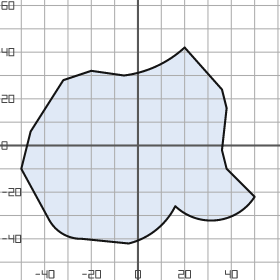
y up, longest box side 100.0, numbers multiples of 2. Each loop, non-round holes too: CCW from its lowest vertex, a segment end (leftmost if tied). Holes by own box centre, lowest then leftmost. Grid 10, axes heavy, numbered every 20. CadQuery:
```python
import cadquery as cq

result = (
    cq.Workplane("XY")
    .moveTo(-4.0, -42.0)
    .threePointArc((8.0, -36.0), (16.0, -26.0))
    .threePointArc((34.0, -32.0), (50.0, -22.0))
    .lineTo(38.0, -10.0)
    .lineTo(36.0, -2.0)
    .lineTo(38.0, 16.0)
    .lineTo(36.0, 24.0)
    .lineTo(20.0, 42.0)
    .threePointArc((8.0, 34.0), (-6.0, 30.0))
    .lineTo(-20.0, 32.0)
    .lineTo(-32.0, 28.0)
    .lineTo(-46.0, 6.0)
    .lineTo(-50.0, -10.0)
    .lineTo(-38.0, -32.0)
    .threePointArc((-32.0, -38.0), (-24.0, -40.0))
    .close()
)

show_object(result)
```